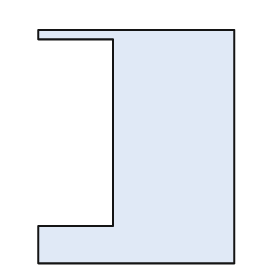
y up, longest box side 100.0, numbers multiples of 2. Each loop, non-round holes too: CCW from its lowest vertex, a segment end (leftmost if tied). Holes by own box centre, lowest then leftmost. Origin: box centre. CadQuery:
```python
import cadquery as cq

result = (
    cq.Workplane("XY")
    .moveTo(-42.0, -50.0)
    .lineTo(42.0, -50.0)
    .lineTo(42.0, 50.0)
    .lineTo(-42.0, 50.0)
    .lineTo(-42.0, 46.0)
    .lineTo(-10.0, 46.0)
    .lineTo(-10.0, -34.0)
    .lineTo(-42.0, -34.0)
    .close()
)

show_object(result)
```